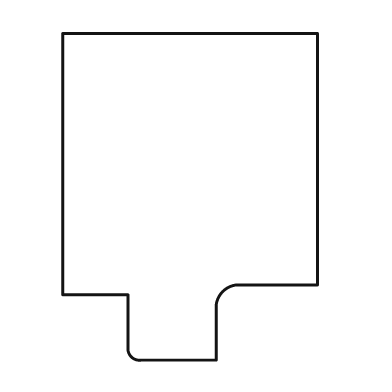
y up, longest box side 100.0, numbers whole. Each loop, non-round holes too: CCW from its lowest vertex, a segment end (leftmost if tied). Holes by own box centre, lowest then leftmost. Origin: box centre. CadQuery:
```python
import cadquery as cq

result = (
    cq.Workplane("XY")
    .moveTo(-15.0, -50.0)
    .lineTo(8.0, -50.0)
    .lineTo(8.0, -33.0)
    .threePointArc((10.0, -29.0), (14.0, -27.0))
    .lineTo(39.0, -27.0)
    .lineTo(39.0, 50.0)
    .lineTo(-39.0, 50.0)
    .lineTo(-39.0, -30.0)
    .lineTo(-19.0, -30.0)
    .lineTo(-19.0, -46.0)
    .threePointArc((-18.0, -49.0), (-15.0, -50.0))
    .close()
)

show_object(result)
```